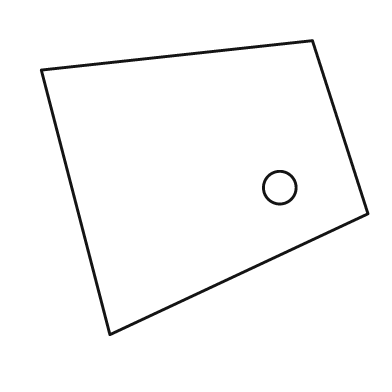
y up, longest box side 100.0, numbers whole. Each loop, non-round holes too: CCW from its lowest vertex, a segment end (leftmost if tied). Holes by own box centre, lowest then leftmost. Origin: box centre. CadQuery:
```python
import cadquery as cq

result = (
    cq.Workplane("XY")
    .moveTo(-29.0, -45.0)
    .lineTo(50.0, -8.0)
    .lineTo(33.0, 45.0)
    .lineTo(-50.0, 36.0)
    .close()
    .moveTo(23.0, 0.0)
    .circle(5.0)
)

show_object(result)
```